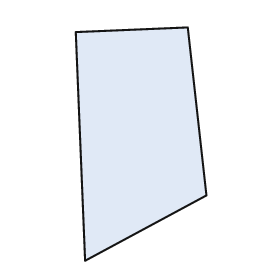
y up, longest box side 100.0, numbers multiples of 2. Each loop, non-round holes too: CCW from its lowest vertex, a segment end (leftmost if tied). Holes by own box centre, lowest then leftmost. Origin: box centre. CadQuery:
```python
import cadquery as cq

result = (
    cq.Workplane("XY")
    .moveTo(-24.0, -50.0)
    .lineTo(28.0, -22.0)
    .lineTo(20.0, 50.0)
    .lineTo(-28.0, 48.0)
    .close()
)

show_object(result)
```